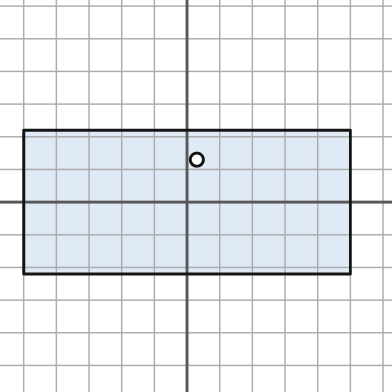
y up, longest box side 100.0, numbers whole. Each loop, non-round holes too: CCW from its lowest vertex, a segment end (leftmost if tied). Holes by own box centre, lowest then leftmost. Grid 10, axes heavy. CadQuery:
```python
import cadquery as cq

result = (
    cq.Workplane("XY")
    .moveTo(-50.0, -22.0)
    .lineTo(50.0, -22.0)
    .lineTo(50.0, 22.0)
    .lineTo(-50.0, 22.0)
    .close()
    .moveTo(3.0, 13.0)
    .circle(2.0)
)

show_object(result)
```